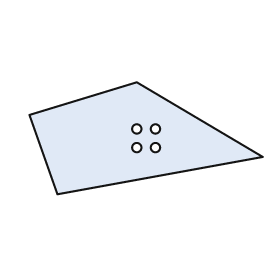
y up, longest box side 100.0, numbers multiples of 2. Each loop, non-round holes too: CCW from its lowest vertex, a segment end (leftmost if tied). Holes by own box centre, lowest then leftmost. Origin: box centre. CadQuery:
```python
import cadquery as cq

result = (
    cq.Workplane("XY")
    .moveTo(-38.0, -24.0)
    .lineTo(50.0, -8.0)
    .lineTo(-4.0, 24.0)
    .lineTo(-50.0, 10.0)
    .close()
    .moveTo(-4.0, -4.0)
    .circle(2.0)
    .moveTo(4.0, -4.0)
    .circle(2.0)
    .moveTo(-4.0, 4.0)
    .circle(2.0)
    .moveTo(4.0, 4.0)
    .circle(2.0)
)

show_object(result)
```